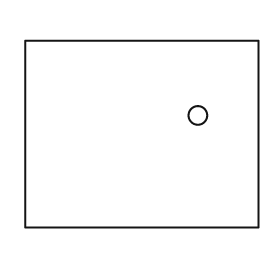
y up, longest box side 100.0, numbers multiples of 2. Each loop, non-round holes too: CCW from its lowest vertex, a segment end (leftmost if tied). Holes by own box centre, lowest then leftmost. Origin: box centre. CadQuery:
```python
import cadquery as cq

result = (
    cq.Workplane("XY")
    .moveTo(-50.0, -40.0)
    .lineTo(50.0, -40.0)
    .lineTo(50.0, 40.0)
    .lineTo(-50.0, 40.0)
    .close()
    .moveTo(24.0, 8.0)
    .circle(4.0)
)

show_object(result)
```